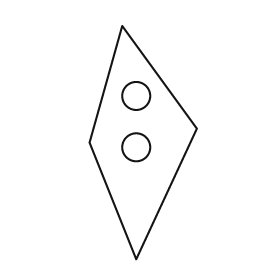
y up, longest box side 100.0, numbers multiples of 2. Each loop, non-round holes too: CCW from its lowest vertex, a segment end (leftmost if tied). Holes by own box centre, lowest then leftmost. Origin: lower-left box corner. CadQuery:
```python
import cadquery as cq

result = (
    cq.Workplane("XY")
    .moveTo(20.0, 0.0)
    .lineTo(46.0, 56.0)
    .lineTo(14.0, 100.0)
    .lineTo(0.0, 50.0)
    .close()
    .moveTo(20.0, 48.0)
    .circle(6.0)
    .moveTo(20.0, 70.0)
    .circle(6.0)
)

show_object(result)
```